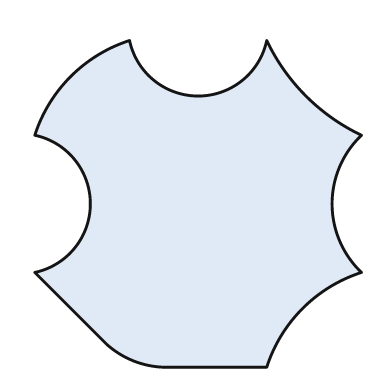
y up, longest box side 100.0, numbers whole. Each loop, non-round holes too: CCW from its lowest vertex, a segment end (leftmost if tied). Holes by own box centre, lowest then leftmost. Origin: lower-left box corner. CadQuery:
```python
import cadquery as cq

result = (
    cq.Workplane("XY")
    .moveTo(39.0, 0.0)
    .lineTo(71.0, 0.0)
    .threePointArc((82.0, 18.0), (100.0, 29.0))
    .threePointArc((91.0, 50.0), (100.0, 71.0))
    .threePointArc((83.0, 83.0), (71.0, 100.0))
    .threePointArc((50.0, 83.0), (29.0, 100.0))
    .threePointArc((11.0, 89.0), (0.0, 71.0))
    .threePointArc((17.0, 50.0), (0.0, 29.0))
    .lineTo(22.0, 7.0)
    .threePointArc((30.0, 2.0), (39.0, 0.0))
    .close()
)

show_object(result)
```